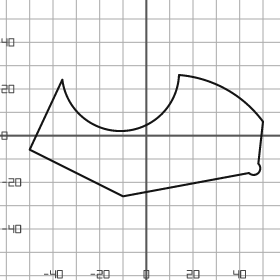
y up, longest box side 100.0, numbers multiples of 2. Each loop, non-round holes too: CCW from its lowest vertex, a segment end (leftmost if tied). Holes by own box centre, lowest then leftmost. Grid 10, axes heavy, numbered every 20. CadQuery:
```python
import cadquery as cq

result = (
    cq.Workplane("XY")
    .moveTo(-10.0, -26.0)
    .lineTo(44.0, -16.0)
    .threePointArc((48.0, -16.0), (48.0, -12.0))
    .lineTo(50.0, 6.0)
    .threePointArc((34.0, 20.0), (14.0, 26.0))
    .threePointArc((-10.0, 2.0), (-36.0, 24.0))
    .lineTo(-50.0, -6.0)
    .close()
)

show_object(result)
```